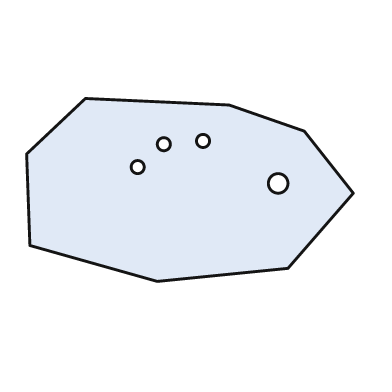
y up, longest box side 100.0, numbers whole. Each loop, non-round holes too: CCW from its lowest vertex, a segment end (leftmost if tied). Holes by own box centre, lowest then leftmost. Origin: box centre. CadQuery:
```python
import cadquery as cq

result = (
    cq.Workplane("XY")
    .moveTo(-10.0, -28.0)
    .lineTo(30.0, -24.0)
    .lineTo(50.0, -1.0)
    .lineTo(35.0, 18.0)
    .lineTo(12.0, 26.0)
    .lineTo(-32.0, 28.0)
    .lineTo(-50.0, 11.0)
    .lineTo(-49.0, -17.0)
    .close()
    .moveTo(27.0, 2.0)
    .circle(3.0)
    .moveTo(-16.0, 7.0)
    .circle(2.0)
    .moveTo(-8.0, 14.0)
    .circle(2.0)
    .moveTo(4.0, 15.0)
    .circle(2.0)
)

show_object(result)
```